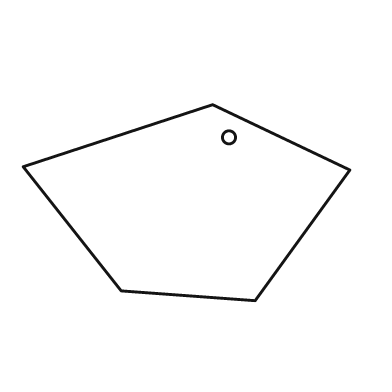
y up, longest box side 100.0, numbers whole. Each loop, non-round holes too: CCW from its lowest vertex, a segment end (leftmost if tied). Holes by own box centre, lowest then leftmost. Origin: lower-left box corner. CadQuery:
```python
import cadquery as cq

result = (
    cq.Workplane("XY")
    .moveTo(71.0, 0.0)
    .lineTo(100.0, 40.0)
    .lineTo(58.0, 60.0)
    .lineTo(0.0, 41.0)
    .lineTo(30.0, 3.0)
    .close()
    .moveTo(63.0, 50.0)
    .circle(2.0)
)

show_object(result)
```